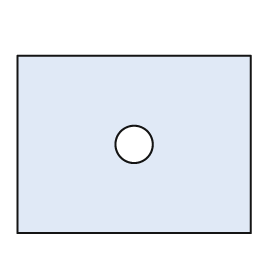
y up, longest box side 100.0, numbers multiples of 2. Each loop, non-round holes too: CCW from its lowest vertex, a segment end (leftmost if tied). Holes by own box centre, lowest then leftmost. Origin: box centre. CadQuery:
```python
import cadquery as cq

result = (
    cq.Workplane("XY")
    .moveTo(-50.0, -38.0)
    .lineTo(50.0, -38.0)
    .lineTo(50.0, 38.0)
    .lineTo(-50.0, 38.0)
    .close()
    .moveTo(0.0, 0.0)
    .circle(8.0)
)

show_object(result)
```